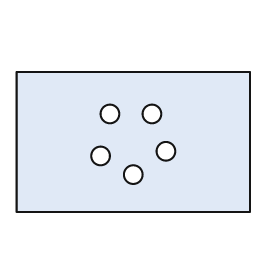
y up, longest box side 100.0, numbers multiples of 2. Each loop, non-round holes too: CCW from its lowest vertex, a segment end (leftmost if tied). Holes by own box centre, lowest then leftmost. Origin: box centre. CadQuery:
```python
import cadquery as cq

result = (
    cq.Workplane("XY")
    .moveTo(-50.0, -30.0)
    .lineTo(50.0, -30.0)
    .lineTo(50.0, 30.0)
    .lineTo(-50.0, 30.0)
    .close()
    .moveTo(0.0, -14.0)
    .circle(4.0)
    .moveTo(-14.0, -6.0)
    .circle(4.0)
    .moveTo(14.0, -4.0)
    .circle(4.0)
    .moveTo(-10.0, 12.0)
    .circle(4.0)
    .moveTo(8.0, 12.0)
    .circle(4.0)
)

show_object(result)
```